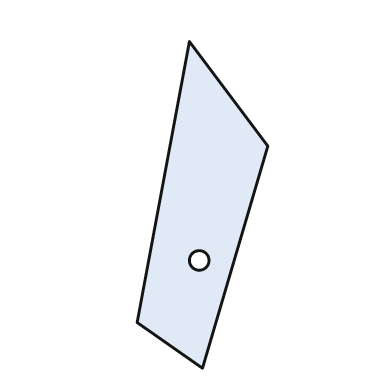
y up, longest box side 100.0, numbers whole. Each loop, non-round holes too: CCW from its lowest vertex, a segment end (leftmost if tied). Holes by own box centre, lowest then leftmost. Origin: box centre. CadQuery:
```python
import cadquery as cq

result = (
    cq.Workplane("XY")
    .moveTo(0.0, -50.0)
    .lineTo(20.0, 18.0)
    .lineTo(-4.0, 50.0)
    .lineTo(-20.0, -36.0)
    .close()
    .moveTo(-1.0, -17.0)
    .circle(3.0)
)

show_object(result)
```